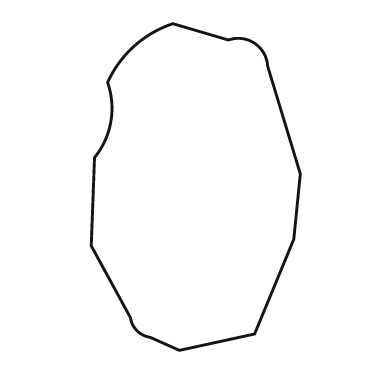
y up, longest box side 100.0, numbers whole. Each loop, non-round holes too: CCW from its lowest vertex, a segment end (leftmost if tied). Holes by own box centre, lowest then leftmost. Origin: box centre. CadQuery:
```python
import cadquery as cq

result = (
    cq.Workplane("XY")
    .moveTo(-5.0, -50.0)
    .lineTo(18.0, -45.0)
    .lineTo(30.0, -16.0)
    .lineTo(32.0, 4.0)
    .lineTo(22.0, 37.0)
    .threePointArc((18.0, 44.0), (10.0, 45.0))
    .lineTo(-7.0, 50.0)
    .threePointArc((-19.0, 43.0), (-27.0, 32.0))
    .threePointArc((-26.0, 20.0), (-31.0, 9.0))
    .lineTo(-32.0, -18.0)
    .lineTo(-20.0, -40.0)
    .threePointArc((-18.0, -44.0), (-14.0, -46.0))
    .close()
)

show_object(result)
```